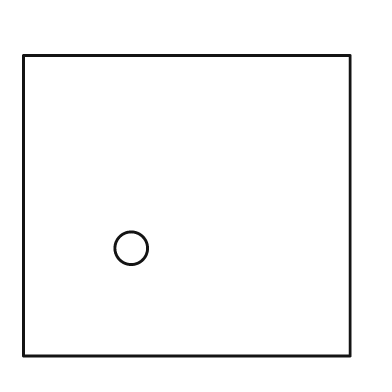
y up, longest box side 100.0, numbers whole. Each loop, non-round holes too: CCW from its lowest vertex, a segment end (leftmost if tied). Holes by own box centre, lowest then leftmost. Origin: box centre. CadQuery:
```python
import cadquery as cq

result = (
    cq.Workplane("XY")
    .moveTo(-50.0, -46.0)
    .lineTo(50.0, -46.0)
    .lineTo(50.0, 46.0)
    .lineTo(-50.0, 46.0)
    .close()
    .moveTo(-17.0, -13.0)
    .circle(5.0)
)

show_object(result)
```